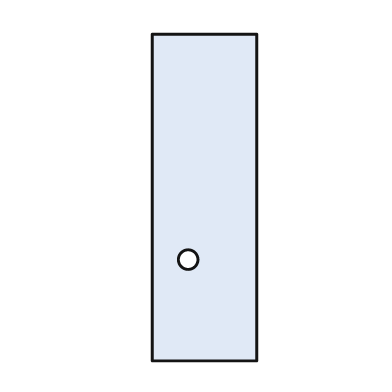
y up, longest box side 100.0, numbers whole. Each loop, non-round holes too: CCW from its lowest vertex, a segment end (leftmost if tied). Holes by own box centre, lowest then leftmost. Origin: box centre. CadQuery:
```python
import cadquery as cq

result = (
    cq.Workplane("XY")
    .moveTo(-16.0, -50.0)
    .lineTo(16.0, -50.0)
    .lineTo(16.0, 50.0)
    .lineTo(-16.0, 50.0)
    .close()
    .moveTo(-5.0, -19.0)
    .circle(3.0)
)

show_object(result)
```